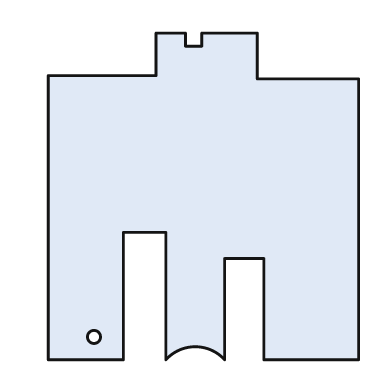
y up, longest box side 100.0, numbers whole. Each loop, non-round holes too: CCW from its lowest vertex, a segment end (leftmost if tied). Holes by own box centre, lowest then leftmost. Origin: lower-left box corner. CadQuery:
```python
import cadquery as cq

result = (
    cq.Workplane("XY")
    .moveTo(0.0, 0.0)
    .lineTo(23.0, 0.0)
    .lineTo(23.0, 39.0)
    .lineTo(36.0, 39.0)
    .lineTo(36.0, 0.0)
    .threePointArc((45.0, 4.0), (54.0, 0.0))
    .lineTo(54.0, 31.0)
    .lineTo(66.0, 31.0)
    .lineTo(66.0, 0.0)
    .lineTo(95.0, 0.0)
    .lineTo(95.0, 86.0)
    .lineTo(64.0, 86.0)
    .lineTo(64.0, 100.0)
    .lineTo(47.0, 100.0)
    .lineTo(47.0, 96.0)
    .lineTo(42.0, 96.0)
    .lineTo(42.0, 100.0)
    .lineTo(33.0, 100.0)
    .lineTo(33.0, 87.0)
    .lineTo(0.0, 87.0)
    .close()
    .moveTo(14.0, 7.0)
    .circle(2.0)
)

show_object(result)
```